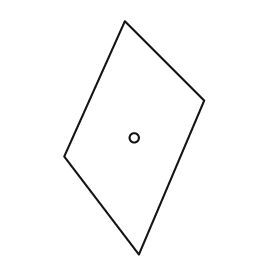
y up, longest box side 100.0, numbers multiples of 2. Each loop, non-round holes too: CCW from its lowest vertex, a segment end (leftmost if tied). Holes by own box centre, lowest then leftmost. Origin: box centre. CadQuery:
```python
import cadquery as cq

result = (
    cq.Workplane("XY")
    .moveTo(2.0, -50.0)
    .lineTo(30.0, 16.0)
    .lineTo(-4.0, 50.0)
    .lineTo(-30.0, -8.0)
    .close()
    .moveTo(0.0, 0.0)
    .circle(2.0)
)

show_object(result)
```